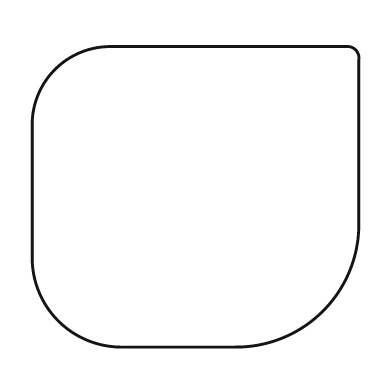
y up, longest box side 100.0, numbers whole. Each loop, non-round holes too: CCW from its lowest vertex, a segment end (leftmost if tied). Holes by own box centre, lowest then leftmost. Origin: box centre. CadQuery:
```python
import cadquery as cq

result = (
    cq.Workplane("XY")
    .moveTo(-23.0, -46.0)
    .lineTo(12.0, -46.0)
    .threePointArc((39.0, -35.0), (50.0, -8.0))
    .lineTo(50.0, 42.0)
    .threePointArc((49.0, 45.0), (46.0, 46.0))
    .lineTo(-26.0, 46.0)
    .threePointArc((-43.0, 39.0), (-50.0, 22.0))
    .lineTo(-50.0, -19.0)
    .threePointArc((-42.0, -38.0), (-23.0, -46.0))
    .close()
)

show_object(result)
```